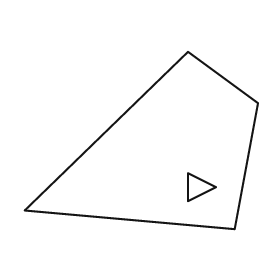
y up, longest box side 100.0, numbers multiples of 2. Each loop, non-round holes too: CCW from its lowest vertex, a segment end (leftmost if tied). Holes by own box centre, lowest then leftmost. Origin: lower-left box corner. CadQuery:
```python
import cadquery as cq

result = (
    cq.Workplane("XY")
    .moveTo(90.0, 0.0)
    .lineTo(100.0, 54.0)
    .lineTo(70.0, 76.0)
    .lineTo(0.0, 8.0)
    .close()
    .moveTo(70.0, 12.0)
    .lineTo(82.0, 18.0)
    .lineTo(70.0, 24.0)
    .close()
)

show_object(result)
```